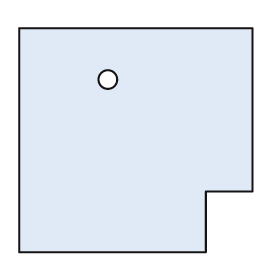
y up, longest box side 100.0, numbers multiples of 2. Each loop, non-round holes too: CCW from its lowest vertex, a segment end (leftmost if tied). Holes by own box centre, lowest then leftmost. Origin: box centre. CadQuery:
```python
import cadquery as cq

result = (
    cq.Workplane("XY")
    .moveTo(-50.0, -48.0)
    .lineTo(30.0, -48.0)
    .lineTo(30.0, -22.0)
    .lineTo(50.0, -22.0)
    .lineTo(50.0, 48.0)
    .lineTo(-50.0, 48.0)
    .close()
    .moveTo(-12.0, 26.0)
    .circle(4.0)
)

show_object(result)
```